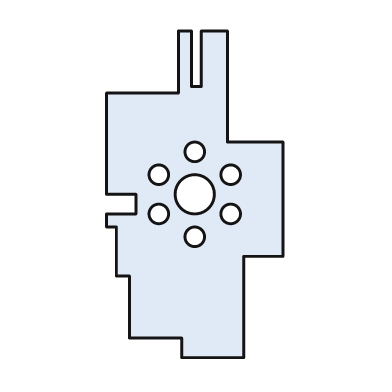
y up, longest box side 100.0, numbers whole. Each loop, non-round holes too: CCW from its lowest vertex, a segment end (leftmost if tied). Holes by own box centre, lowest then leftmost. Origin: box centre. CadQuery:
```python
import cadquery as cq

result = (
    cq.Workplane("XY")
    .moveTo(-4.0, -50.0)
    .lineTo(15.0, -50.0)
    .lineTo(15.0, -19.0)
    .lineTo(27.0, -19.0)
    .lineTo(27.0, 16.0)
    .lineTo(10.0, 16.0)
    .lineTo(10.0, 50.0)
    .lineTo(2.0, 50.0)
    .lineTo(2.0, 33.0)
    .lineTo(-1.0, 33.0)
    .lineTo(-1.0, 50.0)
    .lineTo(-5.0, 50.0)
    .lineTo(-5.0, 31.0)
    .lineTo(-27.0, 31.0)
    .lineTo(-27.0, 0.0)
    .lineTo(-18.0, 0.0)
    .lineTo(-18.0, -6.0)
    .lineTo(-27.0, -6.0)
    .lineTo(-27.0, -10.0)
    .lineTo(-24.0, -10.0)
    .lineTo(-24.0, -25.0)
    .lineTo(-20.0, -25.0)
    .lineTo(-20.0, -44.0)
    .lineTo(-4.0, -44.0)
    .close()
    .moveTo(0.0, -13.0)
    .circle(3.0)
    .moveTo(-11.0, -6.0)
    .circle(3.0)
    .moveTo(11.0, -6.0)
    .circle(3.0)
    .moveTo(0.0, 0.0)
    .circle(6.0)
    .moveTo(-11.0, 6.0)
    .circle(3.0)
    .moveTo(11.0, 6.0)
    .circle(3.0)
    .moveTo(0.0, 13.0)
    .circle(3.0)
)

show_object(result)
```